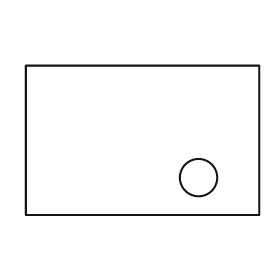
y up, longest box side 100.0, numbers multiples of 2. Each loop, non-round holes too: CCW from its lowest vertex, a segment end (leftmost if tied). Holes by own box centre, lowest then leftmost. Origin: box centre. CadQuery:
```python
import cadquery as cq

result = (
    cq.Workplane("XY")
    .moveTo(-50.0, -32.0)
    .lineTo(50.0, -32.0)
    .lineTo(50.0, 32.0)
    .lineTo(-50.0, 32.0)
    .close()
    .moveTo(24.0, -16.0)
    .circle(8.0)
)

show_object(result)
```